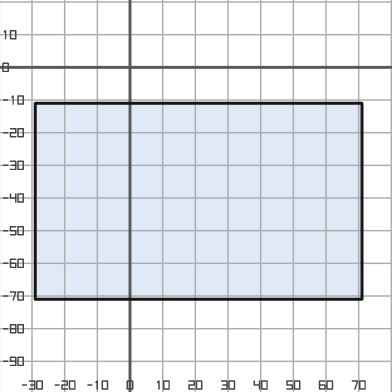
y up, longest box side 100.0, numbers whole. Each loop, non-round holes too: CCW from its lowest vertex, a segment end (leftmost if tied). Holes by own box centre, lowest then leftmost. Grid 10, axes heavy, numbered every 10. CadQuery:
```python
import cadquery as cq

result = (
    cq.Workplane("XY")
    .moveTo(-29.0, -71.0)
    .lineTo(71.0, -71.0)
    .lineTo(71.0, -11.0)
    .lineTo(-29.0, -11.0)
    .close()
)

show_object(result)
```